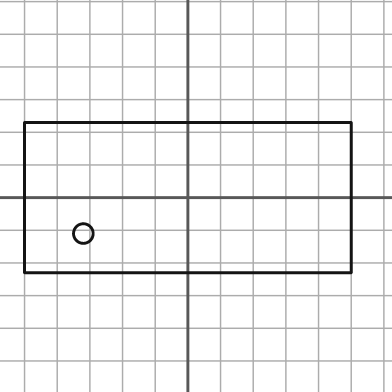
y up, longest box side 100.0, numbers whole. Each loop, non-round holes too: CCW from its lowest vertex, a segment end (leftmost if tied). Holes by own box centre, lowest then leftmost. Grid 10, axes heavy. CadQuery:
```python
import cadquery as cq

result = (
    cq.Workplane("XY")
    .moveTo(-50.0, -23.0)
    .lineTo(50.0, -23.0)
    .lineTo(50.0, 23.0)
    .lineTo(-50.0, 23.0)
    .close()
    .moveTo(-32.0, -11.0)
    .circle(3.0)
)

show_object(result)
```